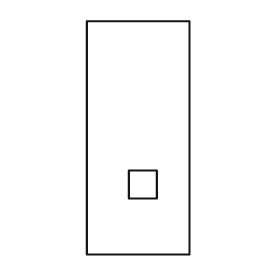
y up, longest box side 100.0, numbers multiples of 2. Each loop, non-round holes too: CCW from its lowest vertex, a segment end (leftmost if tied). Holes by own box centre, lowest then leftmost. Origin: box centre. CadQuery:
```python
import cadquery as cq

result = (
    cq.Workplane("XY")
    .moveTo(-22.0, -50.0)
    .lineTo(22.0, -50.0)
    .lineTo(22.0, 50.0)
    .lineTo(-22.0, 50.0)
    .close()
    .moveTo(-4.0, -26.0)
    .lineTo(8.0, -26.0)
    .lineTo(8.0, -14.0)
    .lineTo(-4.0, -14.0)
    .close()
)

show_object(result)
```